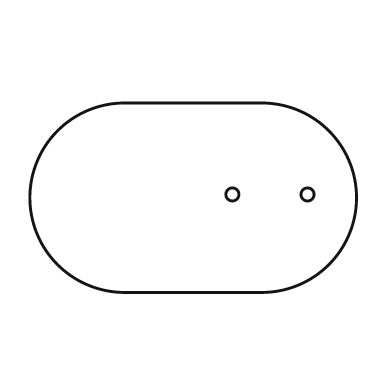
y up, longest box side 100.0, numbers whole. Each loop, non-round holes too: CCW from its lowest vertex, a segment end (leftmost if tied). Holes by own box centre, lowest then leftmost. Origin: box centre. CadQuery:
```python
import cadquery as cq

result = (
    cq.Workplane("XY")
    .moveTo(-21.0, -29.0)
    .lineTo(21.0, -29.0)
    .threePointArc((50.0, 0.0), (21.0, 29.0))
    .lineTo(-21.0, 29.0)
    .threePointArc((-50.0, 0.0), (-21.0, -29.0))
    .close()
    .moveTo(12.0, 1.0)
    .circle(2.0)
    .moveTo(35.0, 1.0)
    .circle(2.0)
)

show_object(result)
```